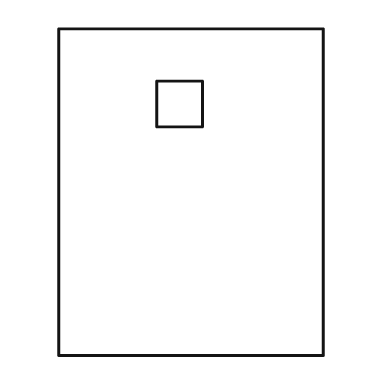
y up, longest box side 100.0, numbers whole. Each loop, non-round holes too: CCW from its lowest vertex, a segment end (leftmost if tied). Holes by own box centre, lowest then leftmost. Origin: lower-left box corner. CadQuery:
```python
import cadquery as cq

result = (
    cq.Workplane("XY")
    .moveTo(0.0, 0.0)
    .lineTo(81.0, 0.0)
    .lineTo(81.0, 100.0)
    .lineTo(0.0, 100.0)
    .close()
    .moveTo(30.0, 70.0)
    .lineTo(44.0, 70.0)
    .lineTo(44.0, 84.0)
    .lineTo(30.0, 84.0)
    .close()
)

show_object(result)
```